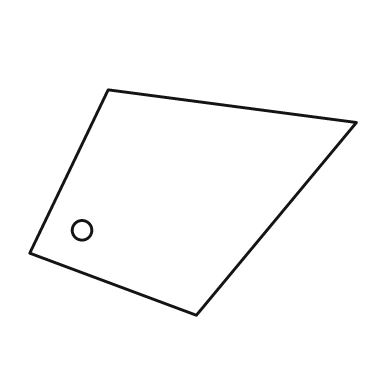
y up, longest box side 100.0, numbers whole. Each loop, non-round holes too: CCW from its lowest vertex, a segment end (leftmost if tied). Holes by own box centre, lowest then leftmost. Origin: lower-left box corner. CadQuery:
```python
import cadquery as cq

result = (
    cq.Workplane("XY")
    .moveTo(51.0, 0.0)
    .lineTo(100.0, 59.0)
    .lineTo(24.0, 69.0)
    .lineTo(0.0, 19.0)
    .close()
    .moveTo(16.0, 26.0)
    .circle(3.0)
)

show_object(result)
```